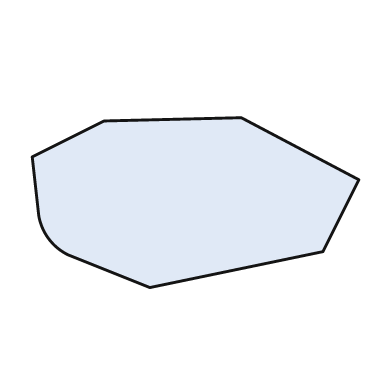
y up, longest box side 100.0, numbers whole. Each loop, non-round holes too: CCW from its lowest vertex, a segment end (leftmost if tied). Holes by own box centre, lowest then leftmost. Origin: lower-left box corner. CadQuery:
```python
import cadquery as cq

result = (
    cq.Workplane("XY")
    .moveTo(36.0, 0.0)
    .lineTo(89.0, 11.0)
    .lineTo(100.0, 33.0)
    .lineTo(64.0, 52.0)
    .lineTo(22.0, 51.0)
    .lineTo(0.0, 40.0)
    .lineTo(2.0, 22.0)
    .threePointArc((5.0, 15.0), (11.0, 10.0))
    .close()
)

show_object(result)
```